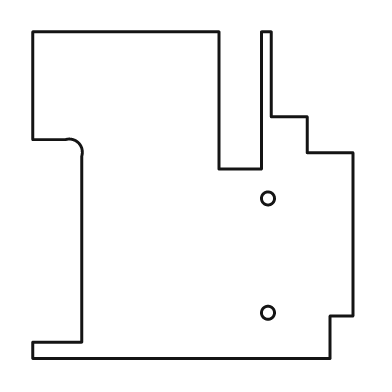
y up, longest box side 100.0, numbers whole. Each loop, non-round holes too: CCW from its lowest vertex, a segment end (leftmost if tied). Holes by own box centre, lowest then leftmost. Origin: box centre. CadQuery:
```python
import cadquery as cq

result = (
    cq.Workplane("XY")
    .moveTo(-49.0, -50.0)
    .lineTo(42.0, -50.0)
    .lineTo(42.0, -37.0)
    .lineTo(49.0, -37.0)
    .lineTo(49.0, 13.0)
    .lineTo(35.0, 13.0)
    .lineTo(35.0, 24.0)
    .lineTo(24.0, 24.0)
    .lineTo(24.0, 50.0)
    .lineTo(21.0, 50.0)
    .lineTo(21.0, 8.0)
    .lineTo(8.0, 8.0)
    .lineTo(8.0, 50.0)
    .lineTo(-49.0, 50.0)
    .lineTo(-49.0, 17.0)
    .lineTo(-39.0, 17.0)
    .threePointArc((-35.0, 16.0), (-34.0, 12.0))
    .lineTo(-34.0, -45.0)
    .lineTo(-49.0, -45.0)
    .close()
    .moveTo(23.0, -36.0)
    .circle(2.0)
    .moveTo(23.0, -1.0)
    .circle(2.0)
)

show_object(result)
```